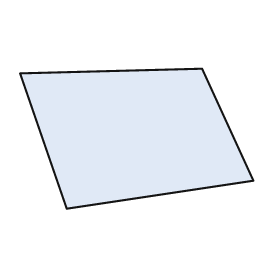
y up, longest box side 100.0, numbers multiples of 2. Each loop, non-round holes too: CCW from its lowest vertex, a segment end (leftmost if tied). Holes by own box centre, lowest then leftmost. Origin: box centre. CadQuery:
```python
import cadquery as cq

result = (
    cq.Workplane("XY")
    .moveTo(-30.0, -30.0)
    .lineTo(50.0, -18.0)
    .lineTo(28.0, 30.0)
    .lineTo(-50.0, 28.0)
    .close()
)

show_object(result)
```